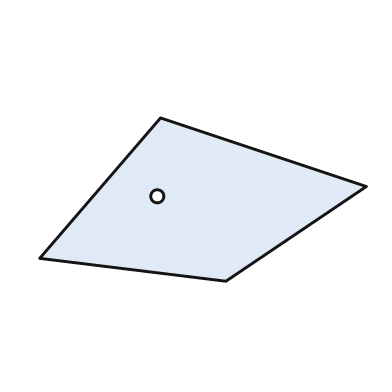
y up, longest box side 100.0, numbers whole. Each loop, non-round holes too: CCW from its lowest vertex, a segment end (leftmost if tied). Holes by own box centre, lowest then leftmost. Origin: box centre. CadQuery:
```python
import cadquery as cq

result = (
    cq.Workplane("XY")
    .moveTo(7.0, -25.0)
    .lineTo(50.0, 4.0)
    .lineTo(-13.0, 25.0)
    .lineTo(-50.0, -18.0)
    .close()
    .moveTo(-14.0, 1.0)
    .circle(2.0)
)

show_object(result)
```